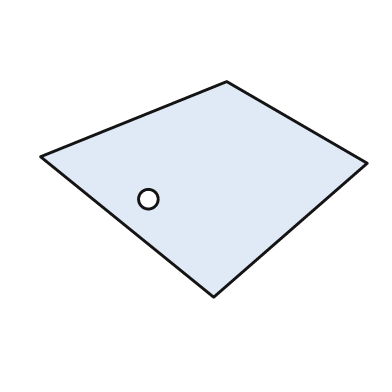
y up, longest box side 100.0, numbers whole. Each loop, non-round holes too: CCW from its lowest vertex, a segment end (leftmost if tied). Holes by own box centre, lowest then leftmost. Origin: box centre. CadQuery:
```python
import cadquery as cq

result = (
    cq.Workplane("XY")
    .moveTo(3.0, -33.0)
    .lineTo(50.0, 8.0)
    .lineTo(7.0, 33.0)
    .lineTo(-50.0, 10.0)
    .close()
    .moveTo(-17.0, -3.0)
    .circle(3.0)
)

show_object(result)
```